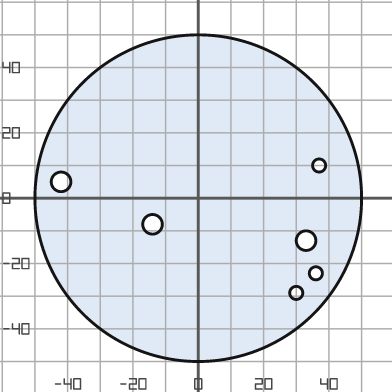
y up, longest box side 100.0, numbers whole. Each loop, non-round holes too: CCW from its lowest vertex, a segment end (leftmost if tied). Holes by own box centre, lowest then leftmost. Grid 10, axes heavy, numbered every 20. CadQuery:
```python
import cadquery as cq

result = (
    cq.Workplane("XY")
    .moveTo(0.0, 0.0)
    .circle(50.0)
    .moveTo(30.0, -29.0)
    .circle(2.0)
    .moveTo(36.0, -23.0)
    .circle(2.0)
    .moveTo(33.0, -13.0)
    .circle(3.0)
    .moveTo(-14.0, -8.0)
    .circle(3.0)
    .moveTo(-42.0, 5.0)
    .circle(3.0)
    .moveTo(37.0, 10.0)
    .circle(2.0)
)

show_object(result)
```